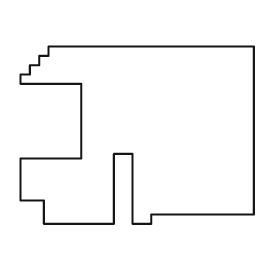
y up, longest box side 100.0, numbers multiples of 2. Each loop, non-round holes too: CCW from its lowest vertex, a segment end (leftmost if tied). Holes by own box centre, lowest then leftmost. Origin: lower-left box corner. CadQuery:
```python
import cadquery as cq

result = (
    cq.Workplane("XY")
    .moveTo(10.0, 0.0)
    .lineTo(40.0, 0.0)
    .lineTo(40.0, 30.0)
    .lineTo(48.0, 30.0)
    .lineTo(48.0, 0.0)
    .lineTo(56.0, 0.0)
    .lineTo(56.0, 4.0)
    .lineTo(100.0, 4.0)
    .lineTo(100.0, 76.0)
    .lineTo(12.0, 76.0)
    .lineTo(12.0, 72.0)
    .lineTo(8.0, 72.0)
    .lineTo(8.0, 68.0)
    .lineTo(4.0, 68.0)
    .lineTo(4.0, 64.0)
    .lineTo(0.0, 64.0)
    .lineTo(0.0, 60.0)
    .lineTo(26.0, 60.0)
    .lineTo(26.0, 28.0)
    .lineTo(0.0, 28.0)
    .lineTo(0.0, 10.0)
    .lineTo(10.0, 10.0)
    .close()
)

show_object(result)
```